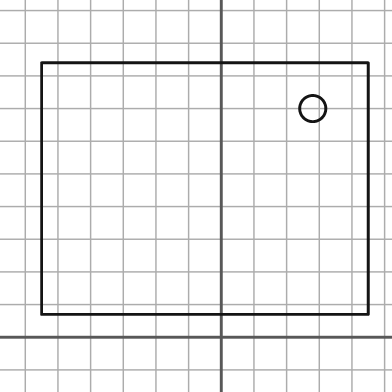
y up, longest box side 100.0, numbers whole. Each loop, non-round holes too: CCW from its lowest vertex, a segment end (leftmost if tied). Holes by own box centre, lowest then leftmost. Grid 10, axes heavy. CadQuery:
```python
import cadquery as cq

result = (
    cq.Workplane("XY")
    .moveTo(-55.0, 7.0)
    .lineTo(45.0, 7.0)
    .lineTo(45.0, 84.0)
    .lineTo(-55.0, 84.0)
    .close()
    .moveTo(28.0, 70.0)
    .circle(4.0)
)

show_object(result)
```